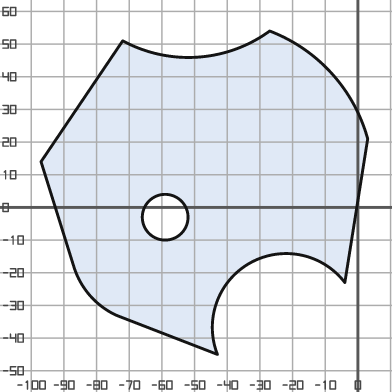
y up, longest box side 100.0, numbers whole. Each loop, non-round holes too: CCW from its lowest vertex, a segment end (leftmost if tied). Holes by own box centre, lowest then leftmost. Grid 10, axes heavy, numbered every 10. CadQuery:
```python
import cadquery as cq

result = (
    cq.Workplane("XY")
    .moveTo(-43.0, -45.0)
    .threePointArc((-33.0, -17.0), (-4.0, -23.0))
    .lineTo(3.0, 21.0)
    .threePointArc((-8.0, 41.0), (-27.0, 54.0))
    .threePointArc((-49.0, 46.0), (-72.0, 51.0))
    .lineTo(-97.0, 14.0)
    .lineTo(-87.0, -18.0)
    .threePointArc((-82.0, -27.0), (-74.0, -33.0))
    .close()
    .moveTo(-59.0, -3.0)
    .circle(7.0)
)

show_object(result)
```